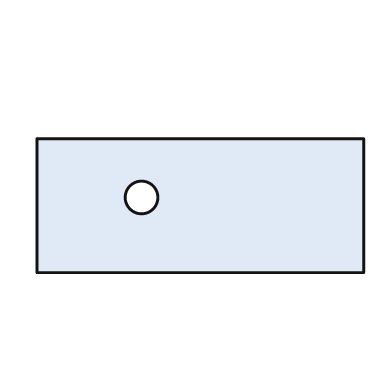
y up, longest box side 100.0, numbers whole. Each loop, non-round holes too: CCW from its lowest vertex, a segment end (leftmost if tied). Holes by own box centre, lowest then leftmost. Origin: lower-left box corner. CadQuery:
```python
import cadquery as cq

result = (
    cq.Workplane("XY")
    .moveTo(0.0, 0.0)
    .lineTo(100.0, 0.0)
    .lineTo(100.0, 41.0)
    .lineTo(0.0, 41.0)
    .close()
    .moveTo(32.0, 23.0)
    .circle(5.0)
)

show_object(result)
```